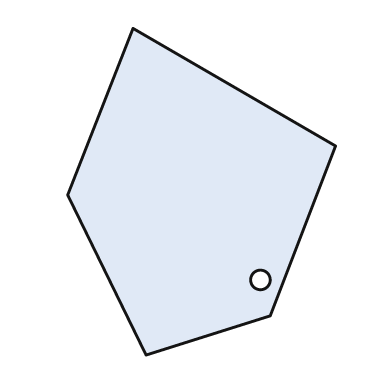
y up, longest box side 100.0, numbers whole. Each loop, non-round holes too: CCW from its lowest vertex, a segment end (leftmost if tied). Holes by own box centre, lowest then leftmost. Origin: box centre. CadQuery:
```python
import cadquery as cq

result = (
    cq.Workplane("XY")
    .moveTo(-17.0, -50.0)
    .lineTo(21.0, -38.0)
    .lineTo(41.0, 14.0)
    .lineTo(-21.0, 50.0)
    .lineTo(-41.0, -1.0)
    .close()
    .moveTo(18.0, -27.0)
    .circle(3.0)
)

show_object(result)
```